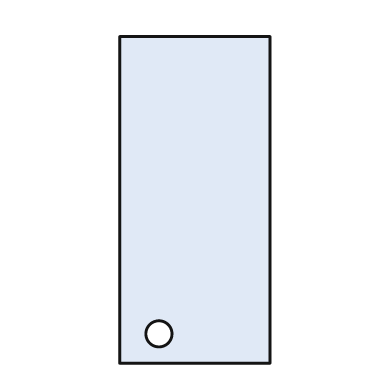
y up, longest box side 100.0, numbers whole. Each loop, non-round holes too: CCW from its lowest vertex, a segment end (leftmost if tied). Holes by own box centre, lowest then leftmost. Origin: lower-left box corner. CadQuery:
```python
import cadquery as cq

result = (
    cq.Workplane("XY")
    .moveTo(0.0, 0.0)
    .lineTo(46.0, 0.0)
    .lineTo(46.0, 100.0)
    .lineTo(0.0, 100.0)
    .close()
    .moveTo(12.0, 9.0)
    .circle(4.0)
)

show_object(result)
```